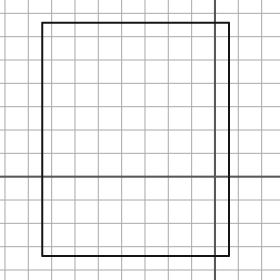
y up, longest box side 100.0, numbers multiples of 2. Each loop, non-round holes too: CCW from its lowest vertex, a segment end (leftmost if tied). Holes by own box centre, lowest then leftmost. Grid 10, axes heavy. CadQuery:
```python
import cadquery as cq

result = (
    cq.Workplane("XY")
    .moveTo(-74.0, -34.0)
    .lineTo(6.0, -34.0)
    .lineTo(6.0, 66.0)
    .lineTo(-74.0, 66.0)
    .close()
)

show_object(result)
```